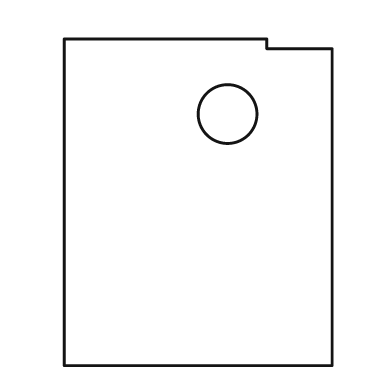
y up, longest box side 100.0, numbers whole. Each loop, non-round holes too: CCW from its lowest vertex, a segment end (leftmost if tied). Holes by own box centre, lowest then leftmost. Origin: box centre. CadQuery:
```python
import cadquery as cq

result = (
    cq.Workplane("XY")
    .moveTo(-41.0, -50.0)
    .lineTo(41.0, -50.0)
    .lineTo(41.0, 47.0)
    .lineTo(21.0, 47.0)
    .lineTo(21.0, 50.0)
    .lineTo(-41.0, 50.0)
    .close()
    .moveTo(9.0, 27.0)
    .circle(9.0)
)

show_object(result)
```